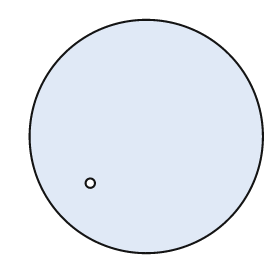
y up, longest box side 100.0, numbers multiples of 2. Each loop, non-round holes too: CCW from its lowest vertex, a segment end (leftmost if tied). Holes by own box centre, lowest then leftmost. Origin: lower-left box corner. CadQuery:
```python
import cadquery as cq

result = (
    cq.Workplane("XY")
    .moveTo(50.0, 50.0)
    .circle(50.0)
    .moveTo(26.0, 30.0)
    .circle(2.0)
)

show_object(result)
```